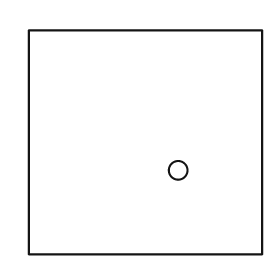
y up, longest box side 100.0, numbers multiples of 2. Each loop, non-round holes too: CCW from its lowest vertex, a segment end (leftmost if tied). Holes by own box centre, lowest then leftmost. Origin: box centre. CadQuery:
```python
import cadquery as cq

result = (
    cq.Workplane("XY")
    .moveTo(-50.0, -48.0)
    .lineTo(50.0, -48.0)
    .lineTo(50.0, 48.0)
    .lineTo(-50.0, 48.0)
    .close()
    .moveTo(14.0, -12.0)
    .circle(4.0)
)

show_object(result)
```